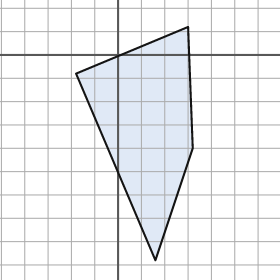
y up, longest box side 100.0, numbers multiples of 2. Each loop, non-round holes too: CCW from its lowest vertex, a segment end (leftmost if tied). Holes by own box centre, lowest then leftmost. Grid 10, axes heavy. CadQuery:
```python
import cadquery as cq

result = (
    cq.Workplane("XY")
    .moveTo(16.0, -88.0)
    .lineTo(32.0, -40.0)
    .lineTo(30.0, 12.0)
    .lineTo(-18.0, -8.0)
    .close()
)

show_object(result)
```